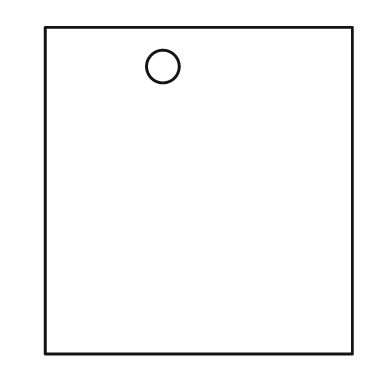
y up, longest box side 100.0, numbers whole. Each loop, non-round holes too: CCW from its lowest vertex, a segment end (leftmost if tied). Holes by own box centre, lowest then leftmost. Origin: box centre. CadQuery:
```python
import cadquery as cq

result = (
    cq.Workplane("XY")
    .moveTo(-47.0, -50.0)
    .lineTo(47.0, -50.0)
    .lineTo(47.0, 50.0)
    .lineTo(-47.0, 50.0)
    .close()
    .moveTo(-11.0, 38.0)
    .circle(5.0)
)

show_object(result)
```